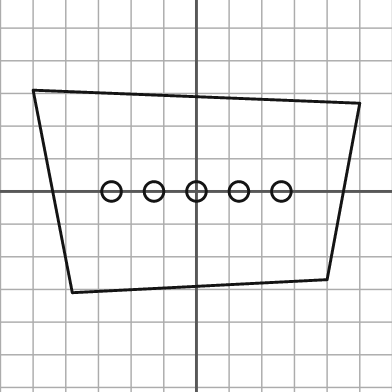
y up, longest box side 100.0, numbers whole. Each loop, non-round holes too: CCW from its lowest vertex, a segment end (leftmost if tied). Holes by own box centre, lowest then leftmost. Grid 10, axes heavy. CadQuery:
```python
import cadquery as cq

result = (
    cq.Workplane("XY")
    .moveTo(-38.0, -31.0)
    .lineTo(40.0, -27.0)
    .lineTo(50.0, 27.0)
    .lineTo(-50.0, 31.0)
    .close()
    .moveTo(-26.0, 0.0)
    .circle(3.0)
    .moveTo(-13.0, 0.0)
    .circle(3.0)
    .moveTo(0.0, 0.0)
    .circle(3.0)
    .moveTo(13.0, 0.0)
    .circle(3.0)
    .moveTo(26.0, 0.0)
    .circle(3.0)
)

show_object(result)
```